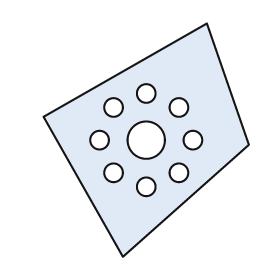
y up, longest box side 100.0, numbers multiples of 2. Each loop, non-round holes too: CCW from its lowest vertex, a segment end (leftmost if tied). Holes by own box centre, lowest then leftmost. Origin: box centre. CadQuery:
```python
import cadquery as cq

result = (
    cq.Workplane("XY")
    .moveTo(-10.0, -50.0)
    .lineTo(44.0, -2.0)
    .lineTo(26.0, 50.0)
    .lineTo(-44.0, 10.0)
    .close()
    .moveTo(0.0, -20.0)
    .circle(4.0)
    .moveTo(-14.0, -14.0)
    .circle(4.0)
    .moveTo(14.0, -14.0)
    .circle(4.0)
    .moveTo(-20.0, 0.0)
    .circle(4.0)
    .moveTo(0.0, 0.0)
    .circle(8.0)
    .moveTo(20.0, 0.0)
    .circle(4.0)
    .moveTo(-14.0, 14.0)
    .circle(4.0)
    .moveTo(14.0, 14.0)
    .circle(4.0)
    .moveTo(0.0, 20.0)
    .circle(4.0)
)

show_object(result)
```